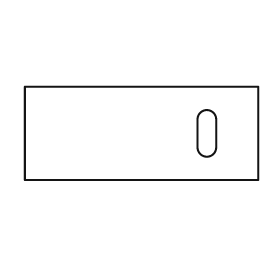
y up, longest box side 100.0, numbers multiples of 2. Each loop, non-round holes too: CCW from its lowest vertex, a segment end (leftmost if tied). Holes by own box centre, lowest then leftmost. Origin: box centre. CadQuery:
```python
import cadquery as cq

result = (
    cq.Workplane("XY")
    .moveTo(-50.0, -20.0)
    .lineTo(50.0, -20.0)
    .lineTo(50.0, 20.0)
    .lineTo(-50.0, 20.0)
    .close()
    .moveTo(24.0, -6.0)
    .threePointArc((28.0, -10.0), (32.0, -6.0))
    .lineTo(32.0, 6.0)
    .threePointArc((28.0, 10.0), (24.0, 6.0))
    .close()
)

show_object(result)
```